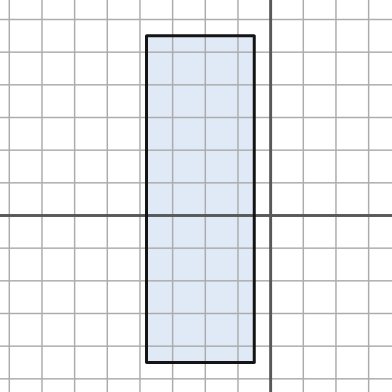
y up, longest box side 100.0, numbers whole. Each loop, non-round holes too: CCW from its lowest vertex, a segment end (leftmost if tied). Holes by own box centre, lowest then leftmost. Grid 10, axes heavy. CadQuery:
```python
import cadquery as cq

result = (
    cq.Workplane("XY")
    .moveTo(-38.0, -45.0)
    .lineTo(-5.0, -45.0)
    .lineTo(-5.0, 55.0)
    .lineTo(-38.0, 55.0)
    .close()
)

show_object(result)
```